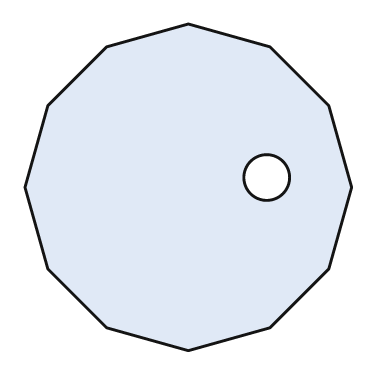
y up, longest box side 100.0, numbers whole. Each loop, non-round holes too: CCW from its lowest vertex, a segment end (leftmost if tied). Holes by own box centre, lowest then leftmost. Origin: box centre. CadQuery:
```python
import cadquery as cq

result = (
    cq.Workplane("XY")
    .moveTo(0.0, -50.0)
    .lineTo(25.0, -43.0)
    .lineTo(43.0, -25.0)
    .lineTo(50.0, 0.0)
    .lineTo(43.0, 25.0)
    .lineTo(25.0, 43.0)
    .lineTo(0.0, 50.0)
    .lineTo(-25.0, 43.0)
    .lineTo(-43.0, 25.0)
    .lineTo(-50.0, 0.0)
    .lineTo(-43.0, -25.0)
    .lineTo(-25.0, -43.0)
    .close()
    .moveTo(24.0, 3.0)
    .circle(7.0)
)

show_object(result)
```